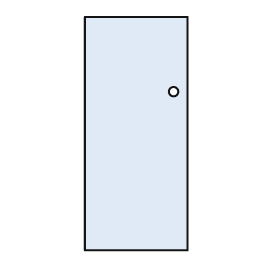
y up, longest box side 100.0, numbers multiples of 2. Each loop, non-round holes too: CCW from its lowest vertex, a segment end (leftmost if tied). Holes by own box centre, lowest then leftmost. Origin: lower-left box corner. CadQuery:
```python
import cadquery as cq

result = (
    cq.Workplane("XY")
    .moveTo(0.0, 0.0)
    .lineTo(44.0, 0.0)
    .lineTo(44.0, 100.0)
    .lineTo(0.0, 100.0)
    .close()
    .moveTo(38.0, 68.0)
    .circle(2.0)
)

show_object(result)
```